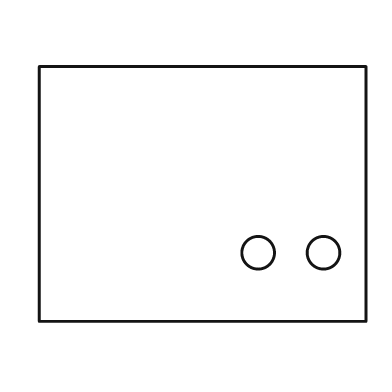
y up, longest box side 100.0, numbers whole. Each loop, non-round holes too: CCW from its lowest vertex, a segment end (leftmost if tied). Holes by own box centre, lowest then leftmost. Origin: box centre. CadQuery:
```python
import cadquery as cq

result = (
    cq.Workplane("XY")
    .moveTo(-50.0, -39.0)
    .lineTo(50.0, -39.0)
    .lineTo(50.0, 39.0)
    .lineTo(-50.0, 39.0)
    .close()
    .moveTo(17.0, -18.0)
    .circle(5.0)
    .moveTo(37.0, -18.0)
    .circle(5.0)
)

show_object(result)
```